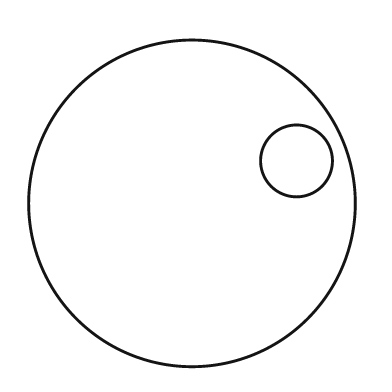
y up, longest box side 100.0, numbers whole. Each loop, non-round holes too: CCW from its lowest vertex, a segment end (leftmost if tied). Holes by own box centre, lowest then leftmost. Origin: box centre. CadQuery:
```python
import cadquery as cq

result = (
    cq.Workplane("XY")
    .moveTo(0.0, 0.0)
    .circle(50.0)
    .moveTo(32.0, 13.0)
    .circle(11.0)
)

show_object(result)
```